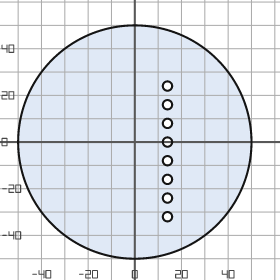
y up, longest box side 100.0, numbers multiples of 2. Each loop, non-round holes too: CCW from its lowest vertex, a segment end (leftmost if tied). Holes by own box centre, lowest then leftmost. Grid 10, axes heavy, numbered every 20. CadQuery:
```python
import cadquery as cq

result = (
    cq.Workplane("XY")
    .moveTo(0.0, 0.0)
    .circle(50.0)
    .moveTo(14.0, -32.0)
    .circle(2.0)
    .moveTo(14.0, -24.0)
    .circle(2.0)
    .moveTo(14.0, -16.0)
    .circle(2.0)
    .moveTo(14.0, -8.0)
    .circle(2.0)
    .moveTo(14.0, 0.0)
    .circle(2.0)
    .moveTo(14.0, 8.0)
    .circle(2.0)
    .moveTo(14.0, 16.0)
    .circle(2.0)
    .moveTo(14.0, 24.0)
    .circle(2.0)
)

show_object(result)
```